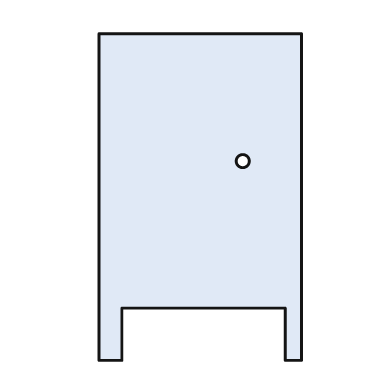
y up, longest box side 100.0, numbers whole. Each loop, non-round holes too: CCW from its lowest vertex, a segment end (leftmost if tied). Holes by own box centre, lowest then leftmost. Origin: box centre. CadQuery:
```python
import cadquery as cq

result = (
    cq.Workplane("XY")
    .moveTo(-31.0, -50.0)
    .lineTo(-24.0, -50.0)
    .lineTo(-24.0, -34.0)
    .lineTo(26.0, -34.0)
    .lineTo(26.0, -50.0)
    .lineTo(31.0, -50.0)
    .lineTo(31.0, 50.0)
    .lineTo(-31.0, 50.0)
    .close()
    .moveTo(13.0, 11.0)
    .circle(2.0)
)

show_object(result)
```